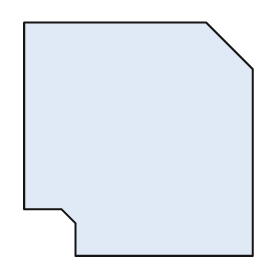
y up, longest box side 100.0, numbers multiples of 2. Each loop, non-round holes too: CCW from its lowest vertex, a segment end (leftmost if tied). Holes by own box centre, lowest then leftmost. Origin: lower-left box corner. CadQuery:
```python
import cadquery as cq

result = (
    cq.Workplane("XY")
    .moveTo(22.0, 0.0)
    .lineTo(98.0, 0.0)
    .lineTo(98.0, 80.0)
    .lineTo(78.0, 100.0)
    .lineTo(0.0, 100.0)
    .lineTo(0.0, 20.0)
    .lineTo(16.0, 20.0)
    .lineTo(22.0, 14.0)
    .close()
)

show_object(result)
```